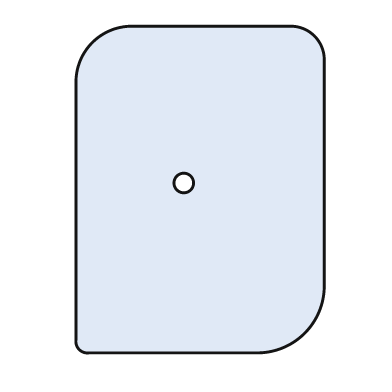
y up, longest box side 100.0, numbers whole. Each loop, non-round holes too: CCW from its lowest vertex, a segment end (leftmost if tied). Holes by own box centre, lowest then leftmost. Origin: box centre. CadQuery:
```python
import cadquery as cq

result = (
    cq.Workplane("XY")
    .moveTo(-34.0, -50.0)
    .lineTo(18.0, -50.0)
    .threePointArc((32.0, -44.0), (38.0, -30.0))
    .lineTo(38.0, 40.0)
    .threePointArc((35.0, 47.0), (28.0, 50.0))
    .lineTo(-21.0, 50.0)
    .threePointArc((-33.0, 45.0), (-38.0, 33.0))
    .lineTo(-38.0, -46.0)
    .threePointArc((-37.0, -49.0), (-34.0, -50.0))
    .close()
    .moveTo(-5.0, 2.0)
    .circle(3.0)
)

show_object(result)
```